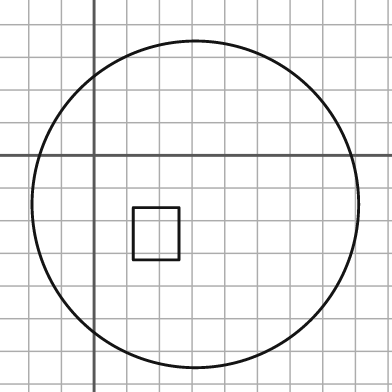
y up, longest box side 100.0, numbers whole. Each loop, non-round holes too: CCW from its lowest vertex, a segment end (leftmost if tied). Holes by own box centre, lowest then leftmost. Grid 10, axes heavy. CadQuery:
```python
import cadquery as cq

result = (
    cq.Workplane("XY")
    .moveTo(31.0, -15.0)
    .circle(50.0)
    .moveTo(12.0, -32.0)
    .lineTo(26.0, -32.0)
    .lineTo(26.0, -16.0)
    .lineTo(12.0, -16.0)
    .close()
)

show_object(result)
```